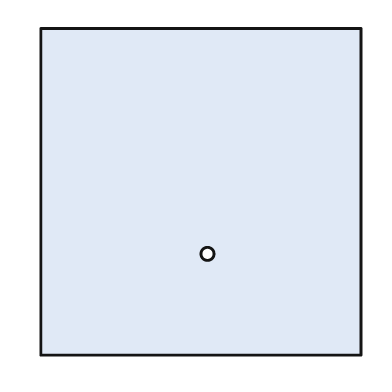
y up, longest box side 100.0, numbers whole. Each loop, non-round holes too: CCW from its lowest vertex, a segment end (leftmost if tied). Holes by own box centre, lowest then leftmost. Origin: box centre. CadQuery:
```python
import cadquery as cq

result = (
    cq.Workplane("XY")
    .moveTo(-49.0, -50.0)
    .lineTo(49.0, -50.0)
    .lineTo(49.0, 50.0)
    .lineTo(-49.0, 50.0)
    .close()
    .moveTo(2.0, -19.0)
    .circle(2.0)
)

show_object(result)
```